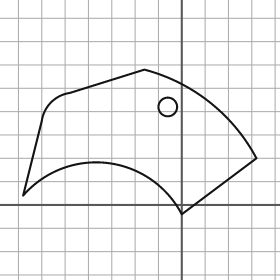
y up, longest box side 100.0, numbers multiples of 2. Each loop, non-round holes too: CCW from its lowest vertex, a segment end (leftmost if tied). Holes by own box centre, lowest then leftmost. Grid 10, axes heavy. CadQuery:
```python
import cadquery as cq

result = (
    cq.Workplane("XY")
    .moveTo(0.0, -4.0)
    .lineTo(32.0, 20.0)
    .threePointArc((12.0, 44.0), (-16.0, 58.0))
    .lineTo(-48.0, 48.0)
    .threePointArc((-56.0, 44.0), (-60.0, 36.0))
    .lineTo(-68.0, 4.0)
    .threePointArc((-32.0, 18.0), (0.0, -4.0))
    .close()
    .moveTo(-6.0, 42.0)
    .circle(4.0)
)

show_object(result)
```